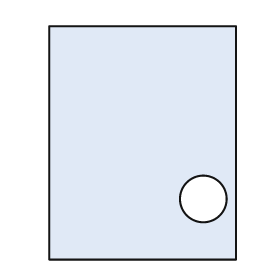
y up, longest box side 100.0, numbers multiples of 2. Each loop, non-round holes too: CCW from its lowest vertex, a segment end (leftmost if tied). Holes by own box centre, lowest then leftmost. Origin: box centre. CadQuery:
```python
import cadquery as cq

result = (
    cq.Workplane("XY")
    .moveTo(-40.0, -50.0)
    .lineTo(40.0, -50.0)
    .lineTo(40.0, 50.0)
    .lineTo(-40.0, 50.0)
    .close()
    .moveTo(26.0, -24.0)
    .circle(10.0)
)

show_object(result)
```